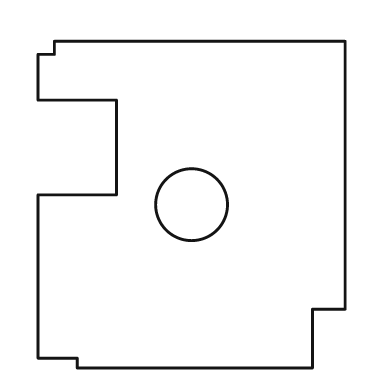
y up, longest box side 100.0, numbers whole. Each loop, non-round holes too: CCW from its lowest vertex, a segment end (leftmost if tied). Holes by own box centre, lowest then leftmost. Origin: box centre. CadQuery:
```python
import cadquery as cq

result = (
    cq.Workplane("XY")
    .moveTo(-35.0, -50.0)
    .lineTo(37.0, -50.0)
    .lineTo(37.0, -32.0)
    .lineTo(47.0, -32.0)
    .lineTo(47.0, 50.0)
    .lineTo(-42.0, 50.0)
    .lineTo(-42.0, 46.0)
    .lineTo(-47.0, 46.0)
    .lineTo(-47.0, 32.0)
    .lineTo(-23.0, 32.0)
    .lineTo(-23.0, 3.0)
    .lineTo(-47.0, 3.0)
    .lineTo(-47.0, -47.0)
    .lineTo(-35.0, -47.0)
    .close()
    .moveTo(0.0, 0.0)
    .circle(11.0)
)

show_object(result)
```